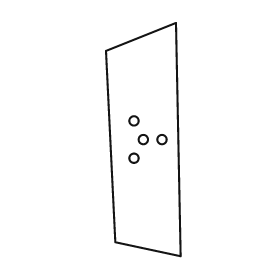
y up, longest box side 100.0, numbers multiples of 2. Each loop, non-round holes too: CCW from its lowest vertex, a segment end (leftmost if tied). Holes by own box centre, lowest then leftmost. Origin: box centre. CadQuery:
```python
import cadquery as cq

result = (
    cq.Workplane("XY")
    .moveTo(16.0, -50.0)
    .lineTo(14.0, 50.0)
    .lineTo(-16.0, 38.0)
    .lineTo(-12.0, -44.0)
    .close()
    .moveTo(-4.0, -8.0)
    .circle(2.0)
    .moveTo(0.0, 0.0)
    .circle(2.0)
    .moveTo(8.0, 0.0)
    .circle(2.0)
    .moveTo(-4.0, 8.0)
    .circle(2.0)
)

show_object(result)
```